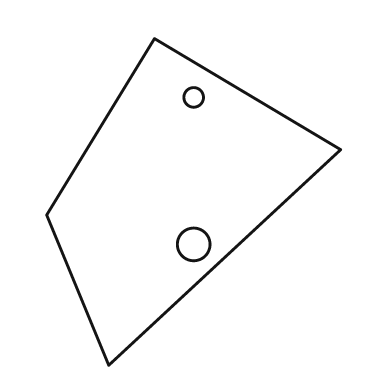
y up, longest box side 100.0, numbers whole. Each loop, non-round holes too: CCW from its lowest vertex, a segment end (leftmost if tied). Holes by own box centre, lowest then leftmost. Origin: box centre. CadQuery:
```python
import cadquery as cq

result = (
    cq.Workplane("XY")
    .moveTo(-26.0, -50.0)
    .lineTo(45.0, 16.0)
    .lineTo(-12.0, 50.0)
    .lineTo(-45.0, -4.0)
    .close()
    .moveTo(0.0, -13.0)
    .circle(5.0)
    .moveTo(0.0, 32.0)
    .circle(3.0)
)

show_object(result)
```